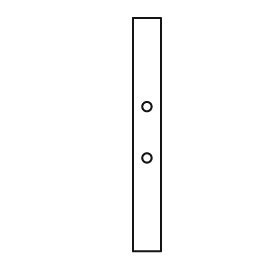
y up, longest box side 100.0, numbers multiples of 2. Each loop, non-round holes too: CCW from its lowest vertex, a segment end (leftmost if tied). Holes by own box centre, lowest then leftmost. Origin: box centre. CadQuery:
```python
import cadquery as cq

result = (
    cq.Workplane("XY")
    .moveTo(-6.0, -50.0)
    .lineTo(6.0, -50.0)
    .lineTo(6.0, 50.0)
    .lineTo(-6.0, 50.0)
    .close()
    .moveTo(0.0, -10.0)
    .circle(2.0)
    .moveTo(0.0, 12.0)
    .circle(2.0)
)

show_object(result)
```